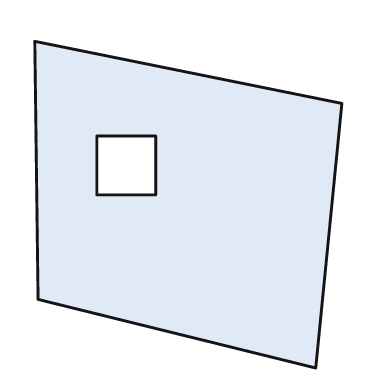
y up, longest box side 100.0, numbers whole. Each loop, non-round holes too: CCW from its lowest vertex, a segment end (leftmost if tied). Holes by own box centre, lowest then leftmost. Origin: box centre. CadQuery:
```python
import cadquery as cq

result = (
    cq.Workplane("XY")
    .moveTo(39.0, -50.0)
    .lineTo(47.0, 31.0)
    .lineTo(-47.0, 50.0)
    .lineTo(-46.0, -29.0)
    .close()
    .moveTo(-28.0, 3.0)
    .lineTo(-10.0, 3.0)
    .lineTo(-10.0, 21.0)
    .lineTo(-28.0, 21.0)
    .close()
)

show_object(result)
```